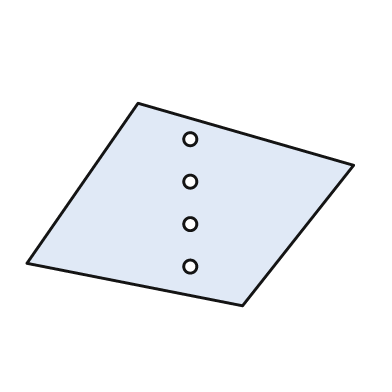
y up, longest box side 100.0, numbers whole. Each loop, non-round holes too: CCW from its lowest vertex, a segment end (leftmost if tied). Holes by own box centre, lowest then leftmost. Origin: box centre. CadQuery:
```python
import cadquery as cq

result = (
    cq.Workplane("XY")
    .moveTo(16.0, -31.0)
    .lineTo(50.0, 12.0)
    .lineTo(-16.0, 31.0)
    .lineTo(-50.0, -18.0)
    .close()
    .moveTo(0.0, -19.0)
    .circle(2.0)
    .moveTo(0.0, -6.0)
    .circle(2.0)
    .moveTo(0.0, 7.0)
    .circle(2.0)
    .moveTo(0.0, 20.0)
    .circle(2.0)
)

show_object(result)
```